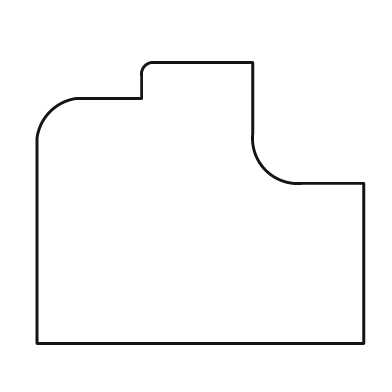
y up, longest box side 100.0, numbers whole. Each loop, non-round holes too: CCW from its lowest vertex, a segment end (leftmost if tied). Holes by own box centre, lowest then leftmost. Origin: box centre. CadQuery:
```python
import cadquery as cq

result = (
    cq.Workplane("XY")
    .moveTo(-50.0, -43.0)
    .lineTo(50.0, -43.0)
    .lineTo(50.0, 6.0)
    .lineTo(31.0, 6.0)
    .threePointArc((20.0, 10.0), (16.0, 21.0))
    .lineTo(16.0, 43.0)
    .lineTo(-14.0, 43.0)
    .threePointArc((-17.0, 42.0), (-18.0, 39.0))
    .lineTo(-18.0, 32.0)
    .lineTo(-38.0, 32.0)
    .threePointArc((-46.0, 28.0), (-50.0, 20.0))
    .close()
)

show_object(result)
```